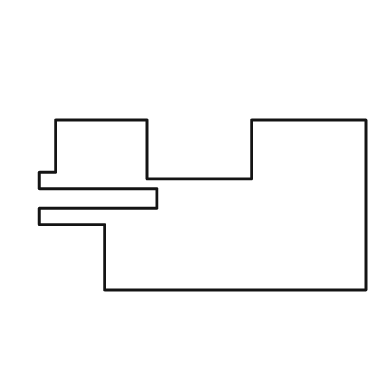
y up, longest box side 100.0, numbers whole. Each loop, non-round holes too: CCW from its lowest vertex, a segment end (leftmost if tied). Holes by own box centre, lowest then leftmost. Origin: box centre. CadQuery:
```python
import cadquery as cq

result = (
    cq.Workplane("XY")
    .moveTo(-30.0, -26.0)
    .lineTo(50.0, -26.0)
    .lineTo(50.0, 26.0)
    .lineTo(15.0, 26.0)
    .lineTo(15.0, 8.0)
    .lineTo(-17.0, 8.0)
    .lineTo(-17.0, 26.0)
    .lineTo(-45.0, 26.0)
    .lineTo(-45.0, 10.0)
    .lineTo(-50.0, 10.0)
    .lineTo(-50.0, 5.0)
    .lineTo(-14.0, 5.0)
    .lineTo(-14.0, -1.0)
    .lineTo(-50.0, -1.0)
    .lineTo(-50.0, -6.0)
    .lineTo(-30.0, -6.0)
    .close()
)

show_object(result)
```